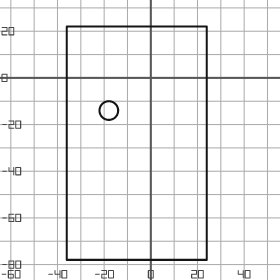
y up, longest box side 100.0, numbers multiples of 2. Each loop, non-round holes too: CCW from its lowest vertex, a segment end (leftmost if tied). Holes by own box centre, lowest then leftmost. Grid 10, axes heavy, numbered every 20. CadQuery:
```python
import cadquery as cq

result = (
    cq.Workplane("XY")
    .moveTo(-36.0, -78.0)
    .lineTo(24.0, -78.0)
    .lineTo(24.0, 22.0)
    .lineTo(-36.0, 22.0)
    .close()
    .moveTo(-18.0, -14.0)
    .circle(4.0)
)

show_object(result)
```